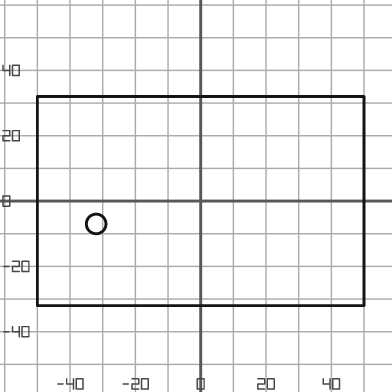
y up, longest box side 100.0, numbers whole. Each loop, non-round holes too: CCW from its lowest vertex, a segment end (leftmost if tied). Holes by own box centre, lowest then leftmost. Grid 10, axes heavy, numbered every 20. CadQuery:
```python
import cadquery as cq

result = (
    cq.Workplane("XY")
    .moveTo(-50.0, -32.0)
    .lineTo(50.0, -32.0)
    .lineTo(50.0, 32.0)
    .lineTo(-50.0, 32.0)
    .close()
    .moveTo(-32.0, -7.0)
    .circle(3.0)
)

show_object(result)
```